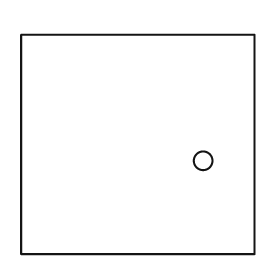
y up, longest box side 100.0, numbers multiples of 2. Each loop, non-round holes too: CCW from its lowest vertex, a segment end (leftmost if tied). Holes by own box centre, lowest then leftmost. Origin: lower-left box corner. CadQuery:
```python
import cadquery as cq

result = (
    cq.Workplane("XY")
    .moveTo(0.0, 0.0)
    .lineTo(100.0, 0.0)
    .lineTo(100.0, 94.0)
    .lineTo(0.0, 94.0)
    .close()
    .moveTo(78.0, 40.0)
    .circle(4.0)
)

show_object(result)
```